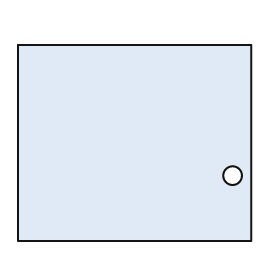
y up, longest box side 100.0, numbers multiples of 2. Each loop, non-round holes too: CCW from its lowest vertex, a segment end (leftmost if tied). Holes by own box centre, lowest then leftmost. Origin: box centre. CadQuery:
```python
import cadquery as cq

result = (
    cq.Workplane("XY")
    .moveTo(-50.0, -42.0)
    .lineTo(50.0, -42.0)
    .lineTo(50.0, 42.0)
    .lineTo(-50.0, 42.0)
    .close()
    .moveTo(42.0, -14.0)
    .circle(4.0)
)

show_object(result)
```